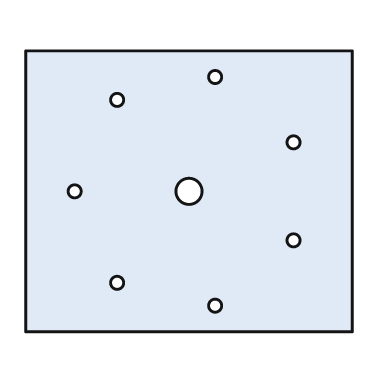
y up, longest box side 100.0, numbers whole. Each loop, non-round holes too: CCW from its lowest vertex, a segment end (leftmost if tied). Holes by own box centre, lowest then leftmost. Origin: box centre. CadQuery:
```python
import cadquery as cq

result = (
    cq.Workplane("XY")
    .moveTo(-50.0, -43.0)
    .lineTo(50.0, -43.0)
    .lineTo(50.0, 43.0)
    .lineTo(-50.0, 43.0)
    .close()
    .moveTo(8.0, -35.0)
    .circle(2.0)
    .moveTo(-22.0, -28.0)
    .circle(2.0)
    .moveTo(32.0, -15.0)
    .circle(2.0)
    .moveTo(-35.0, 0.0)
    .circle(2.0)
    .moveTo(0.0, 0.0)
    .circle(4.0)
    .moveTo(32.0, 15.0)
    .circle(2.0)
    .moveTo(-22.0, 28.0)
    .circle(2.0)
    .moveTo(8.0, 35.0)
    .circle(2.0)
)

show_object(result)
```